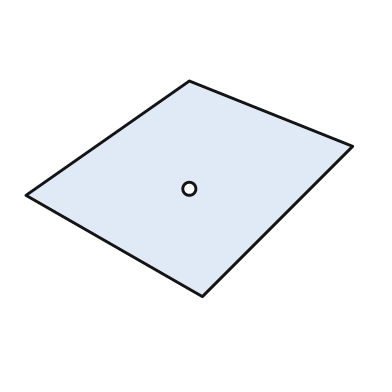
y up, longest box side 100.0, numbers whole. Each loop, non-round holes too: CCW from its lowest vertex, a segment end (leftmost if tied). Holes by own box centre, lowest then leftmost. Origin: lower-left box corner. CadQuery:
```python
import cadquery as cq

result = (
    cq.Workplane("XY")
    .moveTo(54.0, 0.0)
    .lineTo(100.0, 46.0)
    .lineTo(50.0, 66.0)
    .lineTo(0.0, 31.0)
    .close()
    .moveTo(50.0, 33.0)
    .circle(2.0)
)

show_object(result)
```